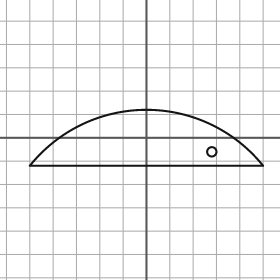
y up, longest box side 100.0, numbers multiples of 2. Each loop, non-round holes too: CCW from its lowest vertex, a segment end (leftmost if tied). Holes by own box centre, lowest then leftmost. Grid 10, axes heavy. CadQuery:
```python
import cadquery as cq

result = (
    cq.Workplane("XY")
    .moveTo(-50.0, -12.0)
    .lineTo(50.0, -12.0)
    .threePointArc((0.0, 12.0), (-50.0, -12.0))
    .close()
    .moveTo(28.0, -6.0)
    .circle(2.0)
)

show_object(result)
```